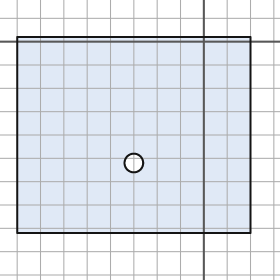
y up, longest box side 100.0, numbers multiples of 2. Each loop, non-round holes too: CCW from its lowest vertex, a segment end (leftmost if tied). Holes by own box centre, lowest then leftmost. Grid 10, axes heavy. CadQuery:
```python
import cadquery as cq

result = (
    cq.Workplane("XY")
    .moveTo(-80.0, -82.0)
    .lineTo(20.0, -82.0)
    .lineTo(20.0, 2.0)
    .lineTo(-80.0, 2.0)
    .close()
    .moveTo(-30.0, -52.0)
    .circle(4.0)
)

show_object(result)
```